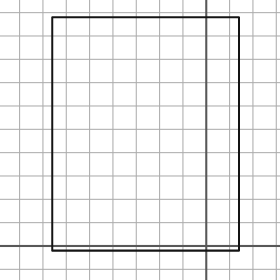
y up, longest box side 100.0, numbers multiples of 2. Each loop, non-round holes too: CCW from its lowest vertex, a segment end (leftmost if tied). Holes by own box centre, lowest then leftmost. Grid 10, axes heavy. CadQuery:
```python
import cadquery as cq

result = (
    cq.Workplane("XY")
    .moveTo(-66.0, -2.0)
    .lineTo(14.0, -2.0)
    .lineTo(14.0, 98.0)
    .lineTo(-66.0, 98.0)
    .close()
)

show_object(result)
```